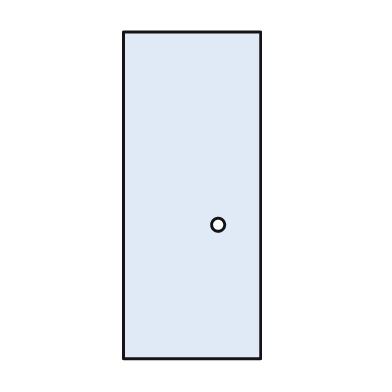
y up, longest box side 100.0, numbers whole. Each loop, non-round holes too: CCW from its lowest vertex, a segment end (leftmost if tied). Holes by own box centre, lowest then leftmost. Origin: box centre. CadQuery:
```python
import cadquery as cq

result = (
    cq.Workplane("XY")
    .moveTo(-21.0, -50.0)
    .lineTo(21.0, -50.0)
    .lineTo(21.0, 50.0)
    .lineTo(-21.0, 50.0)
    .close()
    .moveTo(8.0, -9.0)
    .circle(2.0)
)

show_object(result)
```